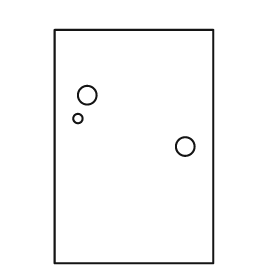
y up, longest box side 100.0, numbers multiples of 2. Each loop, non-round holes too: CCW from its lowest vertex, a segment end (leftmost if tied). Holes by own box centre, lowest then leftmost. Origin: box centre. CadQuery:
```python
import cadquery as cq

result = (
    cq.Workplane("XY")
    .moveTo(-34.0, -50.0)
    .lineTo(34.0, -50.0)
    .lineTo(34.0, 50.0)
    .lineTo(-34.0, 50.0)
    .close()
    .moveTo(22.0, 0.0)
    .circle(4.0)
    .moveTo(-24.0, 12.0)
    .circle(2.0)
    .moveTo(-20.0, 22.0)
    .circle(4.0)
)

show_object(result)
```